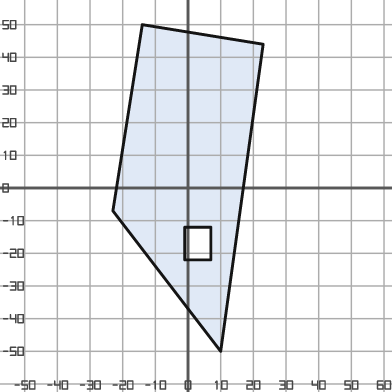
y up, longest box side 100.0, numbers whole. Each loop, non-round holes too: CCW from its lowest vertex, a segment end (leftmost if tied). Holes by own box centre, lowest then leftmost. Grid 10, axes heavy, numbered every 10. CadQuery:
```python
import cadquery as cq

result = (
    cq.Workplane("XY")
    .moveTo(10.0, -50.0)
    .lineTo(23.0, 44.0)
    .lineTo(-14.0, 50.0)
    .lineTo(-23.0, -7.0)
    .close()
    .moveTo(-1.0, -22.0)
    .lineTo(7.0, -22.0)
    .lineTo(7.0, -12.0)
    .lineTo(-1.0, -12.0)
    .close()
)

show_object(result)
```